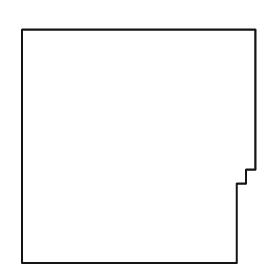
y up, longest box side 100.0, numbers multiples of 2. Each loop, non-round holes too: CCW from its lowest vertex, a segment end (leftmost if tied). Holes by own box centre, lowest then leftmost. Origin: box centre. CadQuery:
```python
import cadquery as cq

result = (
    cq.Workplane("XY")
    .moveTo(-50.0, -50.0)
    .lineTo(42.0, -50.0)
    .lineTo(42.0, -16.0)
    .lineTo(46.0, -16.0)
    .lineTo(46.0, -10.0)
    .lineTo(50.0, -10.0)
    .lineTo(50.0, 50.0)
    .lineTo(-50.0, 50.0)
    .close()
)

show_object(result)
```